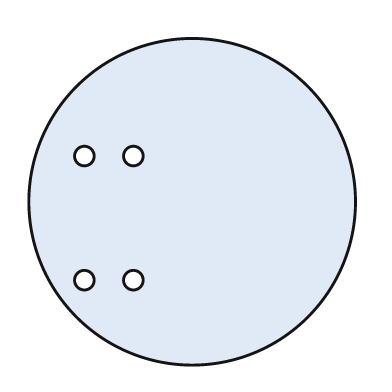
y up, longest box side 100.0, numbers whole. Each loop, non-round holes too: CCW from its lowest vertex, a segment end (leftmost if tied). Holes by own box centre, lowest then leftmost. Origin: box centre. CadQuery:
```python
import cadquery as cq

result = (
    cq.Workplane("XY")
    .moveTo(0.0, 0.0)
    .circle(50.0)
    .moveTo(-33.0, -24.0)
    .circle(3.0)
    .moveTo(-18.0, -24.0)
    .circle(3.0)
    .moveTo(-33.0, 14.0)
    .circle(3.0)
    .moveTo(-18.0, 14.0)
    .circle(3.0)
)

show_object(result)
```